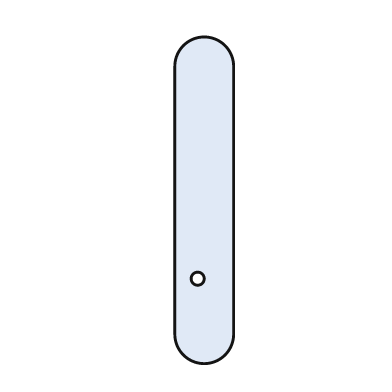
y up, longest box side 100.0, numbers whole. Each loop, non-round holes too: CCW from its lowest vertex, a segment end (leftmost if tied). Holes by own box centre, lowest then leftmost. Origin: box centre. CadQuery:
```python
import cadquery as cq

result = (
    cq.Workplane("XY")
    .moveTo(-9.0, -41.0)
    .threePointArc((0.0, -50.0), (9.0, -41.0))
    .lineTo(9.0, 41.0)
    .threePointArc((0.0, 50.0), (-9.0, 41.0))
    .close()
    .moveTo(-2.0, -24.0)
    .circle(2.0)
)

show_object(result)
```